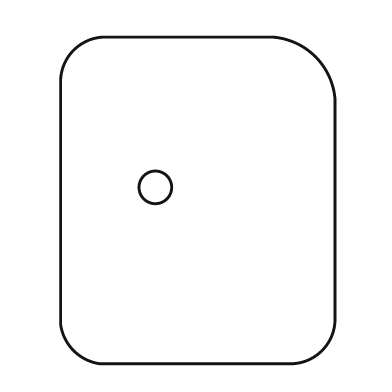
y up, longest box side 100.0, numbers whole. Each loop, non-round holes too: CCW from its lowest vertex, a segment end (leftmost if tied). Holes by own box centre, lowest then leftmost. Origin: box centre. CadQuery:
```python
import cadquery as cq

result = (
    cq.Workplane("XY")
    .moveTo(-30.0, -50.0)
    .lineTo(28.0, -50.0)
    .threePointArc((38.0, -46.0), (42.0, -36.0))
    .lineTo(42.0, 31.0)
    .threePointArc((36.0, 44.0), (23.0, 50.0))
    .lineTo(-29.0, 50.0)
    .threePointArc((-38.0, 46.0), (-42.0, 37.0))
    .lineTo(-42.0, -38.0)
    .threePointArc((-38.0, -46.0), (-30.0, -50.0))
    .close()
    .moveTo(-13.0, 4.0)
    .circle(5.0)
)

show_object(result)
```